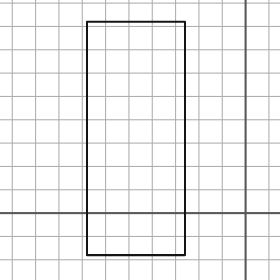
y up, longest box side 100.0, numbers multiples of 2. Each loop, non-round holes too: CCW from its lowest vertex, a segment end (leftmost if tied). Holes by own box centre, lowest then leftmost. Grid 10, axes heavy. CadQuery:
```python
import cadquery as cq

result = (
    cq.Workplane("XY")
    .moveTo(-68.0, -18.0)
    .lineTo(-26.0, -18.0)
    .lineTo(-26.0, 82.0)
    .lineTo(-68.0, 82.0)
    .close()
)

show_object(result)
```